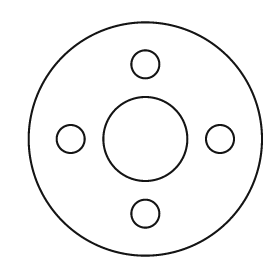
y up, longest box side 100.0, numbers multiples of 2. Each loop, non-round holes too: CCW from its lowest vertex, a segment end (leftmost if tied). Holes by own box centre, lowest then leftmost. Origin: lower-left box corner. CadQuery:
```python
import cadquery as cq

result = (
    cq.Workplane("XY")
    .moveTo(50.0, 50.0)
    .circle(50.0)
    .moveTo(50.0, 18.0)
    .circle(6.0)
    .moveTo(18.0, 50.0)
    .circle(6.0)
    .moveTo(50.0, 50.0)
    .circle(18.0)
    .moveTo(82.0, 50.0)
    .circle(6.0)
    .moveTo(50.0, 82.0)
    .circle(6.0)
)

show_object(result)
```